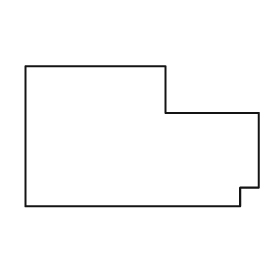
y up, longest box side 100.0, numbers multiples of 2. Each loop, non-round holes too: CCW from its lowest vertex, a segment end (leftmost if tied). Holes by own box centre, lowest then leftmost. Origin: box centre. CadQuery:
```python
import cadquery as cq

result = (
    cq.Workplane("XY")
    .moveTo(-50.0, -30.0)
    .lineTo(42.0, -30.0)
    .lineTo(42.0, -22.0)
    .lineTo(50.0, -22.0)
    .lineTo(50.0, 10.0)
    .lineTo(10.0, 10.0)
    .lineTo(10.0, 30.0)
    .lineTo(-50.0, 30.0)
    .close()
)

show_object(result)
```